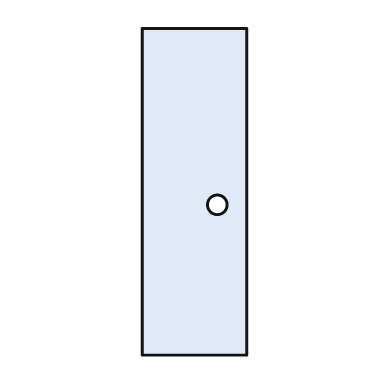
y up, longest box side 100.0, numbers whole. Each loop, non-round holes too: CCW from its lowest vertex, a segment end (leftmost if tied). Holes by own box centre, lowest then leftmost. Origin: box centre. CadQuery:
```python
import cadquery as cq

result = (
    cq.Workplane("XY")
    .moveTo(-16.0, -50.0)
    .lineTo(16.0, -50.0)
    .lineTo(16.0, 50.0)
    .lineTo(-16.0, 50.0)
    .close()
    .moveTo(7.0, -4.0)
    .circle(3.0)
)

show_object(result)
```